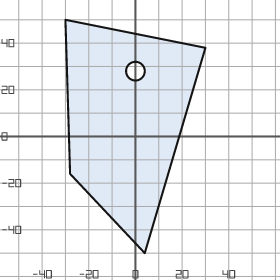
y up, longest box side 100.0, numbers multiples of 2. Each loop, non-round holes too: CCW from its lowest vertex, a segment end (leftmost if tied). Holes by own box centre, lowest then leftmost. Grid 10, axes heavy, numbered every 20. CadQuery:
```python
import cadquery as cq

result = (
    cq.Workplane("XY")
    .moveTo(4.0, -50.0)
    .lineTo(30.0, 38.0)
    .lineTo(-30.0, 50.0)
    .lineTo(-28.0, -16.0)
    .close()
    .moveTo(0.0, 28.0)
    .circle(4.0)
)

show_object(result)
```